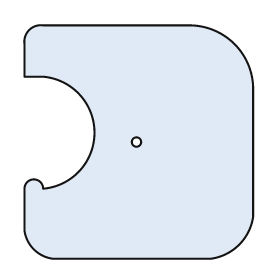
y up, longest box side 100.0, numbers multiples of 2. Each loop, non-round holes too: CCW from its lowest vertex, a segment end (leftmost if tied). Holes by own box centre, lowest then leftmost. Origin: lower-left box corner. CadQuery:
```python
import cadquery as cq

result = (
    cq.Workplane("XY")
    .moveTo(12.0, 0.0)
    .lineTo(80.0, 0.0)
    .threePointArc((92.0, 6.0), (98.0, 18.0))
    .lineTo(98.0, 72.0)
    .threePointArc((90.0, 92.0), (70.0, 100.0))
    .lineTo(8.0, 100.0)
    .threePointArc((2.0, 98.0), (0.0, 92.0))
    .lineTo(0.0, 78.0)
    .lineTo(8.0, 78.0)
    .threePointArc((30.0, 54.0), (8.0, 30.0))
    .threePointArc((4.0, 34.0), (0.0, 30.0))
    .lineTo(0.0, 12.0)
    .threePointArc((4.0, 4.0), (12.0, 0.0))
    .close()
    .moveTo(48.0, 50.0)
    .circle(2.0)
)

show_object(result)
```